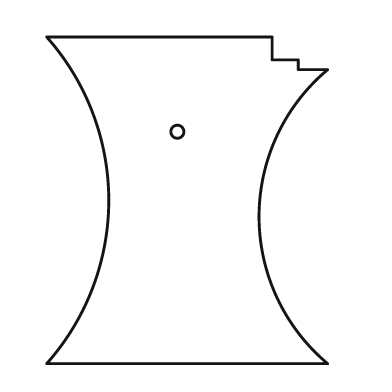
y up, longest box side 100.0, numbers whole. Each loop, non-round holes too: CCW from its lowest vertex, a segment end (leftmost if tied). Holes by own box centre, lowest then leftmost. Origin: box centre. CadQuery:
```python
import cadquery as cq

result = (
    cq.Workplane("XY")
    .moveTo(-43.0, -50.0)
    .lineTo(43.0, -50.0)
    .threePointArc((22.0, -5.0), (43.0, 40.0))
    .lineTo(34.0, 40.0)
    .lineTo(34.0, 43.0)
    .lineTo(26.0, 43.0)
    .lineTo(26.0, 50.0)
    .lineTo(-43.0, 50.0)
    .threePointArc((-24.0, 0.0), (-43.0, -50.0))
    .close()
    .moveTo(-3.0, 21.0)
    .circle(2.0)
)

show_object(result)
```